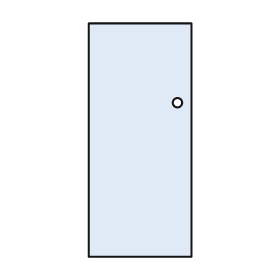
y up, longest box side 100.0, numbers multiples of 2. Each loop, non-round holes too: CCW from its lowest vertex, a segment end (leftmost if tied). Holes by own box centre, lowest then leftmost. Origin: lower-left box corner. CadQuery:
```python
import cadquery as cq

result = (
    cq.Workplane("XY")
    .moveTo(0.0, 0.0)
    .lineTo(44.0, 0.0)
    .lineTo(44.0, 100.0)
    .lineTo(0.0, 100.0)
    .close()
    .moveTo(38.0, 66.0)
    .circle(2.0)
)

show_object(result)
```